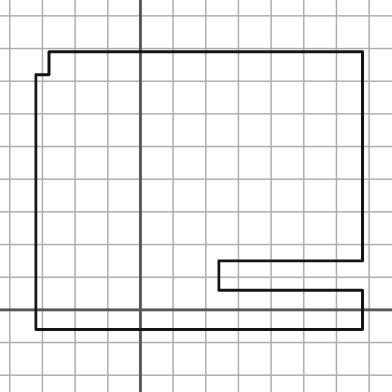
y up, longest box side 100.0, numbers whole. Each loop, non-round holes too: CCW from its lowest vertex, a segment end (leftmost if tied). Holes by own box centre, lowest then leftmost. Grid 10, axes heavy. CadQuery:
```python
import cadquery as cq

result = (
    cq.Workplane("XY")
    .moveTo(-32.0, -6.0)
    .lineTo(68.0, -6.0)
    .lineTo(68.0, 6.0)
    .lineTo(24.0, 6.0)
    .lineTo(24.0, 15.0)
    .lineTo(68.0, 15.0)
    .lineTo(68.0, 79.0)
    .lineTo(-28.0, 79.0)
    .lineTo(-28.0, 72.0)
    .lineTo(-32.0, 72.0)
    .close()
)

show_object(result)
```